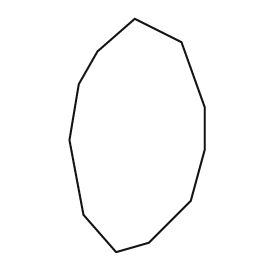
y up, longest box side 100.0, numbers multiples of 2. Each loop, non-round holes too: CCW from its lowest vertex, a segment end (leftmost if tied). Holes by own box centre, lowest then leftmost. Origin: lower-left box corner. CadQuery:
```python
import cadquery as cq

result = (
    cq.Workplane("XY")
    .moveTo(20.0, 0.0)
    .lineTo(34.0, 4.0)
    .lineTo(52.0, 22.0)
    .lineTo(58.0, 44.0)
    .lineTo(58.0, 62.0)
    .lineTo(48.0, 90.0)
    .lineTo(28.0, 100.0)
    .lineTo(12.0, 86.0)
    .lineTo(4.0, 72.0)
    .lineTo(0.0, 48.0)
    .lineTo(6.0, 16.0)
    .close()
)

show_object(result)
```